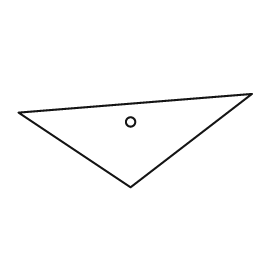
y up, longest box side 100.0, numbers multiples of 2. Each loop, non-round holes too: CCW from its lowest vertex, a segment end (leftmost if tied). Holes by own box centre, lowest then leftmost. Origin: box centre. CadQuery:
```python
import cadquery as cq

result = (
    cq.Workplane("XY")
    .moveTo(-2.0, -20.0)
    .lineTo(50.0, 20.0)
    .lineTo(-50.0, 12.0)
    .close()
    .moveTo(-2.0, 8.0)
    .circle(2.0)
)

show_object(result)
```